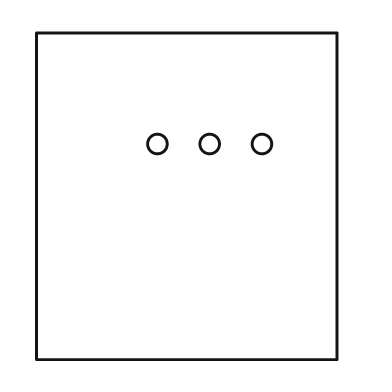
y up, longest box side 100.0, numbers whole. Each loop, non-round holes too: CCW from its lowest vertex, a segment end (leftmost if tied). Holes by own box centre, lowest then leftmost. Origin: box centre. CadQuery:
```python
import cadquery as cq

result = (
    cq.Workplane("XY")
    .moveTo(-46.0, -50.0)
    .lineTo(46.0, -50.0)
    .lineTo(46.0, 50.0)
    .lineTo(-46.0, 50.0)
    .close()
    .moveTo(-9.0, 16.0)
    .circle(3.0)
    .moveTo(7.0, 16.0)
    .circle(3.0)
    .moveTo(23.0, 16.0)
    .circle(3.0)
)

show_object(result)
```